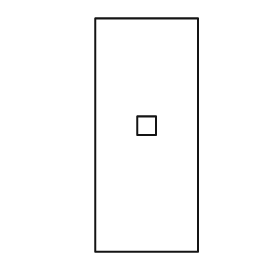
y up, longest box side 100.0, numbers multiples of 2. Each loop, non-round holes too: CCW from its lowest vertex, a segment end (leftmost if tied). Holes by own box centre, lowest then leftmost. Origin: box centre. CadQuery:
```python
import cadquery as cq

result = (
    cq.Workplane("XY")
    .moveTo(-22.0, -50.0)
    .lineTo(22.0, -50.0)
    .lineTo(22.0, 50.0)
    .lineTo(-22.0, 50.0)
    .close()
    .moveTo(-4.0, 0.0)
    .lineTo(4.0, 0.0)
    .lineTo(4.0, 8.0)
    .lineTo(-4.0, 8.0)
    .close()
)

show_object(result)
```